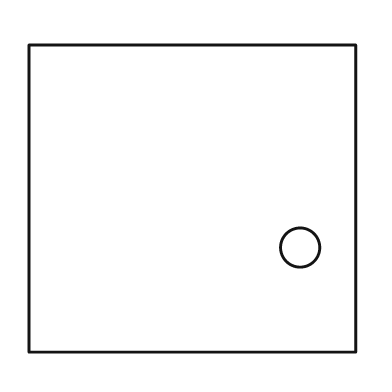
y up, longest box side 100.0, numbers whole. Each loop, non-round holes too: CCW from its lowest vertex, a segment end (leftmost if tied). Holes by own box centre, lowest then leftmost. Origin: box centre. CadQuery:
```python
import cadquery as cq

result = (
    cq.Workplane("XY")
    .moveTo(-50.0, -47.0)
    .lineTo(50.0, -47.0)
    .lineTo(50.0, 47.0)
    .lineTo(-50.0, 47.0)
    .close()
    .moveTo(33.0, -15.0)
    .circle(6.0)
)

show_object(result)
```